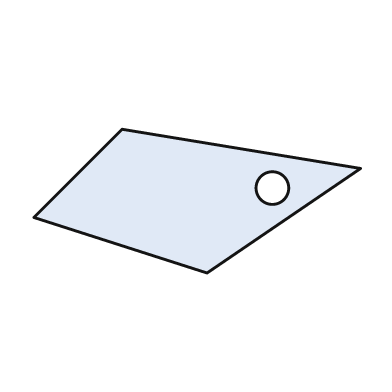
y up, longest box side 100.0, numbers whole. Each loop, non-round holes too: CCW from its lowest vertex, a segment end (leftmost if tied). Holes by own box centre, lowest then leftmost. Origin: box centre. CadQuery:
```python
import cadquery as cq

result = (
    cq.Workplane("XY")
    .moveTo(3.0, -22.0)
    .lineTo(50.0, 10.0)
    .lineTo(-23.0, 22.0)
    .lineTo(-50.0, -5.0)
    .close()
    .moveTo(23.0, 4.0)
    .circle(5.0)
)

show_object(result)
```